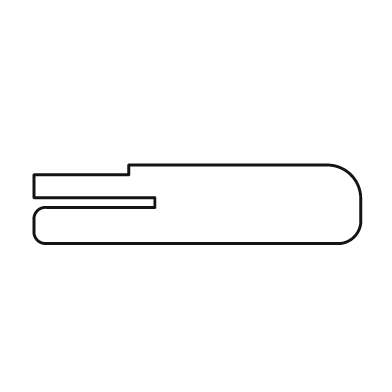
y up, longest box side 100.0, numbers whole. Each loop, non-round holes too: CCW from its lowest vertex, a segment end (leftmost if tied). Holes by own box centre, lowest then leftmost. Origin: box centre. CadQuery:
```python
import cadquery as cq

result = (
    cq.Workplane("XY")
    .moveTo(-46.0, -12.0)
    .lineTo(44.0, -12.0)
    .threePointArc((48.0, -10.0), (50.0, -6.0))
    .lineTo(50.0, 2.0)
    .threePointArc((47.0, 9.0), (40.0, 12.0))
    .lineTo(-21.0, 12.0)
    .lineTo(-21.0, 9.0)
    .lineTo(-50.0, 9.0)
    .lineTo(-50.0, 2.0)
    .lineTo(-13.0, 2.0)
    .lineTo(-13.0, -1.0)
    .lineTo(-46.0, -1.0)
    .threePointArc((-49.0, -2.0), (-50.0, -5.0))
    .lineTo(-50.0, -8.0)
    .threePointArc((-49.0, -11.0), (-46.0, -12.0))
    .close()
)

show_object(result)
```